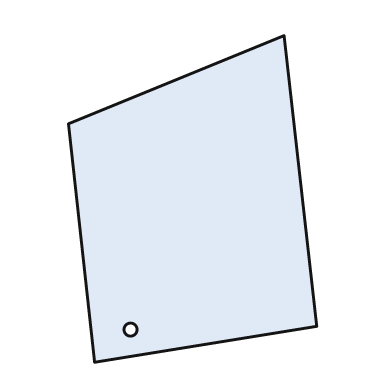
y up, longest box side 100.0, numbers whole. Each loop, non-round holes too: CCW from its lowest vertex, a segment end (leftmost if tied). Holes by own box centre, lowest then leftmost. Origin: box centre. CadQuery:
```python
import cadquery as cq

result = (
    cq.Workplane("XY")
    .moveTo(-30.0, -50.0)
    .lineTo(38.0, -39.0)
    .lineTo(28.0, 50.0)
    .lineTo(-38.0, 23.0)
    .close()
    .moveTo(-19.0, -40.0)
    .circle(2.0)
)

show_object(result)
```